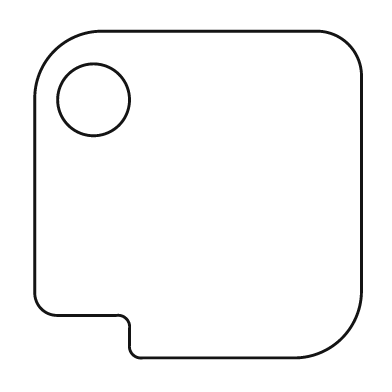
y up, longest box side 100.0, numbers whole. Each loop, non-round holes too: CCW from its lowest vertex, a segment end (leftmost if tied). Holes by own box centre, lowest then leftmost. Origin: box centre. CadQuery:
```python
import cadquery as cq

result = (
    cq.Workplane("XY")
    .moveTo(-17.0, -50.0)
    .lineTo(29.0, -50.0)
    .threePointArc((44.0, -44.0), (50.0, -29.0))
    .lineTo(50.0, 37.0)
    .threePointArc((46.0, 46.0), (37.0, 50.0))
    .lineTo(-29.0, 50.0)
    .threePointArc((-44.0, 44.0), (-50.0, 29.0))
    .lineTo(-50.0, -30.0)
    .threePointArc((-48.0, -35.0), (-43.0, -37.0))
    .lineTo(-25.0, -37.0)
    .threePointArc((-22.0, -38.0), (-21.0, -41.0))
    .lineTo(-21.0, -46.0)
    .threePointArc((-20.0, -49.0), (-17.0, -50.0))
    .close()
    .moveTo(-32.0, 29.0)
    .circle(11.0)
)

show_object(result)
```